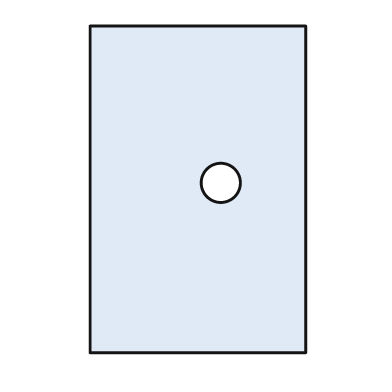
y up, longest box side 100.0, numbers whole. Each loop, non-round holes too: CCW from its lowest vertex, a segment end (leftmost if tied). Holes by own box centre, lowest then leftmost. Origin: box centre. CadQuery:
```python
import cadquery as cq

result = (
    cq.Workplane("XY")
    .moveTo(-33.0, -50.0)
    .lineTo(33.0, -50.0)
    .lineTo(33.0, 50.0)
    .lineTo(-33.0, 50.0)
    .close()
    .moveTo(7.0, 2.0)
    .circle(6.0)
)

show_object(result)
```